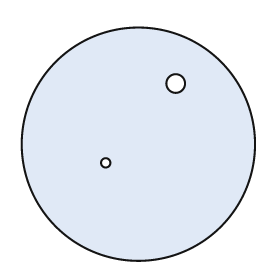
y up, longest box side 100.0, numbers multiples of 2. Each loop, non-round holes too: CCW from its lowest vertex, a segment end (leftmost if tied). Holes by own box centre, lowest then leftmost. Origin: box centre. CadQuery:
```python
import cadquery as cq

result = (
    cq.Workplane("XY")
    .moveTo(0.0, 0.0)
    .circle(50.0)
    .moveTo(-14.0, -8.0)
    .circle(2.0)
    .moveTo(16.0, 26.0)
    .circle(4.0)
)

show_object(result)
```